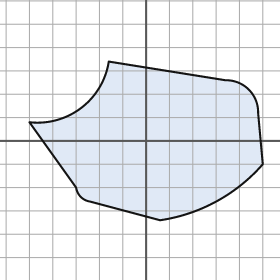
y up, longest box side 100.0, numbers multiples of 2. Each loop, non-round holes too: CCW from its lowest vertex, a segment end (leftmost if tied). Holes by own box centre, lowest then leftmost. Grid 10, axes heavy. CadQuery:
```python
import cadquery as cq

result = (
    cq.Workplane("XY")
    .moveTo(6.0, -34.0)
    .threePointArc((30.0, -26.0), (50.0, -10.0))
    .lineTo(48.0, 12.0)
    .threePointArc((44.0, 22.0), (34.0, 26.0))
    .lineTo(-16.0, 34.0)
    .threePointArc((-28.0, 14.0), (-50.0, 8.0))
    .lineTo(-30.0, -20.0)
    .threePointArc((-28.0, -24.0), (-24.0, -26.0))
    .close()
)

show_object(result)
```